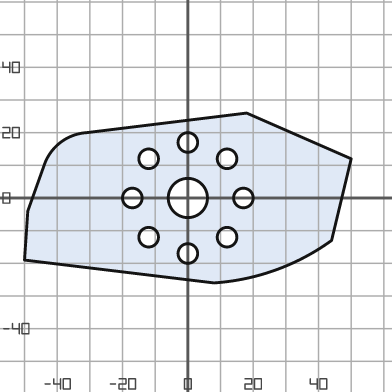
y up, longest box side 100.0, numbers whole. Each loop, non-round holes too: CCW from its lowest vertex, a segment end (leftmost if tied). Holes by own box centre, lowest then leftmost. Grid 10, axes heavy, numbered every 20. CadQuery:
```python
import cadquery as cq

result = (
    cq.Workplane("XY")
    .moveTo(8.0, -26.0)
    .threePointArc((27.0, -22.0), (44.0, -13.0))
    .lineTo(50.0, 12.0)
    .lineTo(18.0, 26.0)
    .lineTo(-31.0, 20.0)
    .threePointArc((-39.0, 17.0), (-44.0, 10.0))
    .lineTo(-49.0, -4.0)
    .lineTo(-50.0, -19.0)
    .close()
    .moveTo(0.0, -17.0)
    .circle(3.0)
    .moveTo(-12.0, -12.0)
    .circle(3.0)
    .moveTo(12.0, -12.0)
    .circle(3.0)
    .moveTo(-17.0, 0.0)
    .circle(3.0)
    .moveTo(0.0, 0.0)
    .circle(6.0)
    .moveTo(17.0, 0.0)
    .circle(3.0)
    .moveTo(-12.0, 12.0)
    .circle(3.0)
    .moveTo(12.0, 12.0)
    .circle(3.0)
    .moveTo(0.0, 17.0)
    .circle(3.0)
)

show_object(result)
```